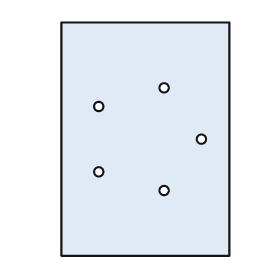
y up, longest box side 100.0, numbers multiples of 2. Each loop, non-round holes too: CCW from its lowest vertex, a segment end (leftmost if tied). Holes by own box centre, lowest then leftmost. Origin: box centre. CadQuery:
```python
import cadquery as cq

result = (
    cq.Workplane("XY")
    .moveTo(-36.0, -50.0)
    .lineTo(36.0, -50.0)
    .lineTo(36.0, 50.0)
    .lineTo(-36.0, 50.0)
    .close()
    .moveTo(8.0, -22.0)
    .circle(2.0)
    .moveTo(-20.0, -14.0)
    .circle(2.0)
    .moveTo(24.0, 0.0)
    .circle(2.0)
    .moveTo(-20.0, 14.0)
    .circle(2.0)
    .moveTo(8.0, 22.0)
    .circle(2.0)
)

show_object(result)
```